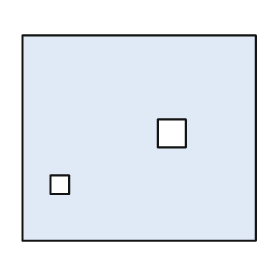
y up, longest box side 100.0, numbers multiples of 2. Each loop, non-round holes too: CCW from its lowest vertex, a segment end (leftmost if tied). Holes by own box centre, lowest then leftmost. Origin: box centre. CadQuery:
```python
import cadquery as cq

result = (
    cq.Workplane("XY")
    .moveTo(-50.0, -44.0)
    .lineTo(50.0, -44.0)
    .lineTo(50.0, 44.0)
    .lineTo(-50.0, 44.0)
    .close()
    .moveTo(-38.0, -24.0)
    .lineTo(-30.0, -24.0)
    .lineTo(-30.0, -16.0)
    .lineTo(-38.0, -16.0)
    .close()
    .moveTo(8.0, -4.0)
    .lineTo(20.0, -4.0)
    .lineTo(20.0, 8.0)
    .lineTo(8.0, 8.0)
    .close()
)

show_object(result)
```